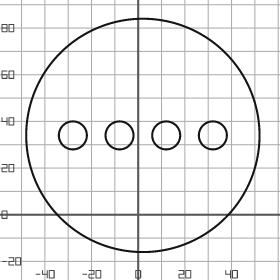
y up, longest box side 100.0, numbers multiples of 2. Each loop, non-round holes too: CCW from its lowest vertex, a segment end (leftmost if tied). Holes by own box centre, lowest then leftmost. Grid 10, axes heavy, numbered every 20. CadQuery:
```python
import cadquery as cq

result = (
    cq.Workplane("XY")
    .moveTo(2.0, 34.0)
    .circle(50.0)
    .moveTo(-28.0, 34.0)
    .circle(6.0)
    .moveTo(-8.0, 34.0)
    .circle(6.0)
    .moveTo(12.0, 34.0)
    .circle(6.0)
    .moveTo(32.0, 34.0)
    .circle(6.0)
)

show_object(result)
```